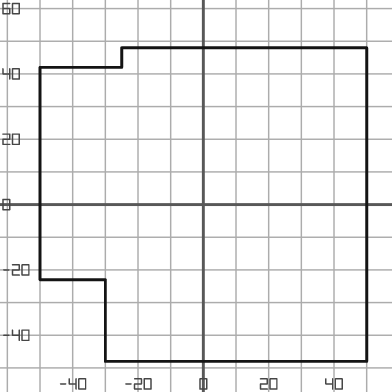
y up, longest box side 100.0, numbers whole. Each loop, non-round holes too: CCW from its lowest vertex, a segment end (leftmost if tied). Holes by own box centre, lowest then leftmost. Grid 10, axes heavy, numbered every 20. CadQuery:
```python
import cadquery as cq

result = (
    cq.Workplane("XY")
    .moveTo(-30.0, -48.0)
    .lineTo(50.0, -48.0)
    .lineTo(50.0, 48.0)
    .lineTo(-25.0, 48.0)
    .lineTo(-25.0, 42.0)
    .lineTo(-50.0, 42.0)
    .lineTo(-50.0, -23.0)
    .lineTo(-30.0, -23.0)
    .close()
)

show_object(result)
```